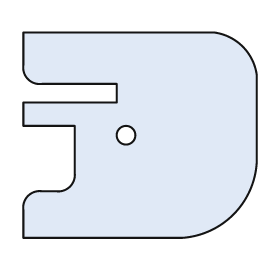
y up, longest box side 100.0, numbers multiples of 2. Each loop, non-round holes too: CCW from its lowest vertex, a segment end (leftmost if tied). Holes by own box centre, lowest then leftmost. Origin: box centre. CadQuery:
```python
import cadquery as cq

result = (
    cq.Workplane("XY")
    .moveTo(-50.0, -44.0)
    .lineTo(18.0, -44.0)
    .threePointArc((40.0, -34.0), (50.0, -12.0))
    .lineTo(50.0, 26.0)
    .threePointArc((44.0, 38.0), (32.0, 44.0))
    .lineTo(-50.0, 44.0)
    .lineTo(-50.0, 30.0)
    .threePointArc((-48.0, 24.0), (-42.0, 22.0))
    .lineTo(-10.0, 22.0)
    .lineTo(-10.0, 14.0)
    .lineTo(-50.0, 14.0)
    .lineTo(-50.0, 4.0)
    .lineTo(-28.0, 4.0)
    .lineTo(-28.0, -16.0)
    .threePointArc((-30.0, -22.0), (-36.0, -24.0))
    .lineTo(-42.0, -24.0)
    .threePointArc((-48.0, -26.0), (-50.0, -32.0))
    .close()
    .moveTo(-6.0, 0.0)
    .circle(4.0)
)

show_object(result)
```